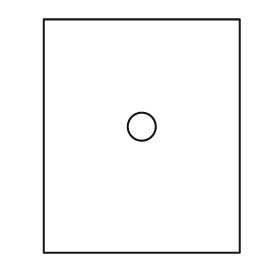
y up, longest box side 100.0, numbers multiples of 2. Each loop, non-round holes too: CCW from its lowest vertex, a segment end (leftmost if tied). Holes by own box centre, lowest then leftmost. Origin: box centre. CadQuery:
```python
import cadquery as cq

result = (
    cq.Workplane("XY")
    .moveTo(-42.0, -50.0)
    .lineTo(42.0, -50.0)
    .lineTo(42.0, 50.0)
    .lineTo(-42.0, 50.0)
    .close()
    .moveTo(0.0, 4.0)
    .circle(6.0)
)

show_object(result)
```